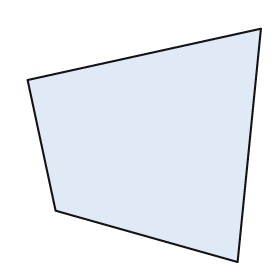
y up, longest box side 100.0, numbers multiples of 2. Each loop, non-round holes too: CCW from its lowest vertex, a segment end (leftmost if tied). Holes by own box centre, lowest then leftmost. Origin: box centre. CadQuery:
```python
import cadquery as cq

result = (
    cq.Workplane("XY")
    .moveTo(40.0, -50.0)
    .lineTo(50.0, 50.0)
    .lineTo(-50.0, 28.0)
    .lineTo(-38.0, -28.0)
    .close()
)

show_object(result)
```